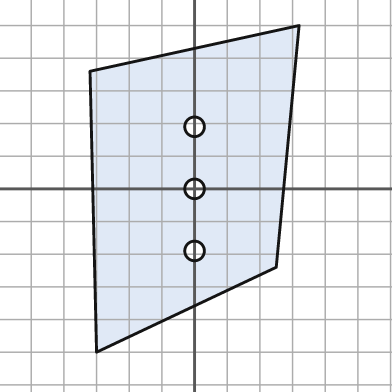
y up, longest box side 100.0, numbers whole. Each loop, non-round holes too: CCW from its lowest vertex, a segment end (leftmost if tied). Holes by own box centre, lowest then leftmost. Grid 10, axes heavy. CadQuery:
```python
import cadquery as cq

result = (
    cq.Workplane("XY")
    .moveTo(-30.0, -50.0)
    .lineTo(25.0, -24.0)
    .lineTo(32.0, 50.0)
    .lineTo(-32.0, 36.0)
    .close()
    .moveTo(0.0, -19.0)
    .circle(3.0)
    .moveTo(0.0, 0.0)
    .circle(3.0)
    .moveTo(0.0, 19.0)
    .circle(3.0)
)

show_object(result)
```